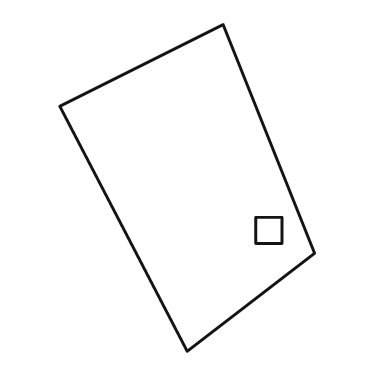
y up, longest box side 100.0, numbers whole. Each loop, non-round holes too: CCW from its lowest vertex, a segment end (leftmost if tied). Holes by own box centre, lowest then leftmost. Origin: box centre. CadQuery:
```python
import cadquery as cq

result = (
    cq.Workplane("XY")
    .moveTo(0.0, -50.0)
    .lineTo(39.0, -20.0)
    .lineTo(11.0, 50.0)
    .lineTo(-39.0, 25.0)
    .close()
    .moveTo(21.0, -17.0)
    .lineTo(29.0, -17.0)
    .lineTo(29.0, -9.0)
    .lineTo(21.0, -9.0)
    .close()
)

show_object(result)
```